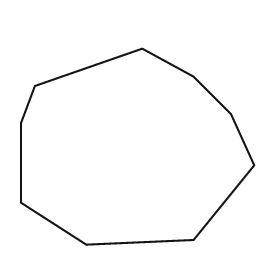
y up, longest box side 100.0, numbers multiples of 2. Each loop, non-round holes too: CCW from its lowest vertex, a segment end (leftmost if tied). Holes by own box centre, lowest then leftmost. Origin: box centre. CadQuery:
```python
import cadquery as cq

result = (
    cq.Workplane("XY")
    .moveTo(-22.0, -42.0)
    .lineTo(24.0, -40.0)
    .lineTo(50.0, -8.0)
    .lineTo(40.0, 14.0)
    .lineTo(24.0, 30.0)
    .lineTo(2.0, 42.0)
    .lineTo(-44.0, 26.0)
    .lineTo(-50.0, 10.0)
    .lineTo(-50.0, -24.0)
    .close()
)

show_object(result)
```